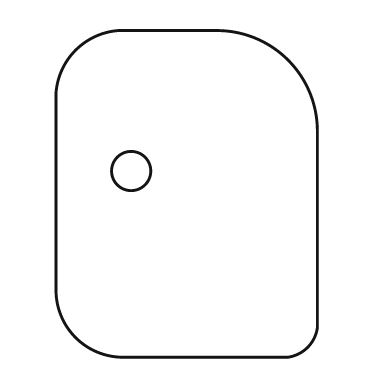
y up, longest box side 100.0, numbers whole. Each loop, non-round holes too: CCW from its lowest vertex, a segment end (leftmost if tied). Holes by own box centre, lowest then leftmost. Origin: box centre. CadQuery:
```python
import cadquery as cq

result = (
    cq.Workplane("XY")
    .moveTo(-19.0, -50.0)
    .lineTo(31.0, -50.0)
    .threePointArc((37.0, -47.0), (40.0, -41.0))
    .lineTo(40.0, 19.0)
    .threePointArc((31.0, 41.0), (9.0, 50.0))
    .lineTo(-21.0, 50.0)
    .threePointArc((-34.0, 44.0), (-40.0, 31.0))
    .lineTo(-40.0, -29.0)
    .threePointArc((-34.0, -44.0), (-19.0, -50.0))
    .close()
    .moveTo(-17.0, 7.0)
    .circle(6.0)
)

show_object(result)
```